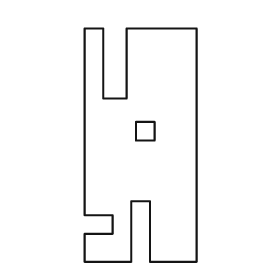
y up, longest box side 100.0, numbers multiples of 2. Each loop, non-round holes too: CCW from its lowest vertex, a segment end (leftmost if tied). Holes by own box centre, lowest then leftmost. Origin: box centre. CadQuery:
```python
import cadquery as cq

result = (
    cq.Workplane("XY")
    .moveTo(-24.0, -50.0)
    .lineTo(-4.0, -50.0)
    .lineTo(-4.0, -24.0)
    .lineTo(4.0, -24.0)
    .lineTo(4.0, -50.0)
    .lineTo(24.0, -50.0)
    .lineTo(24.0, 50.0)
    .lineTo(-6.0, 50.0)
    .lineTo(-6.0, 20.0)
    .lineTo(-16.0, 20.0)
    .lineTo(-16.0, 50.0)
    .lineTo(-24.0, 50.0)
    .lineTo(-24.0, -30.0)
    .lineTo(-12.0, -30.0)
    .lineTo(-12.0, -38.0)
    .lineTo(-24.0, -38.0)
    .close()
    .moveTo(-2.0, 2.0)
    .lineTo(6.0, 2.0)
    .lineTo(6.0, 10.0)
    .lineTo(-2.0, 10.0)
    .close()
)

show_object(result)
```